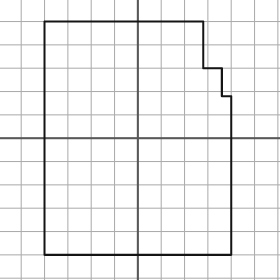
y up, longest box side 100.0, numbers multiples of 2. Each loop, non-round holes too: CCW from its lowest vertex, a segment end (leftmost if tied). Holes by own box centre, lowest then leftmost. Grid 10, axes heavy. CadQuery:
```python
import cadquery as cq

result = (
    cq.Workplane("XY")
    .moveTo(-40.0, -50.0)
    .lineTo(40.0, -50.0)
    .lineTo(40.0, 18.0)
    .lineTo(36.0, 18.0)
    .lineTo(36.0, 30.0)
    .lineTo(28.0, 30.0)
    .lineTo(28.0, 50.0)
    .lineTo(-40.0, 50.0)
    .close()
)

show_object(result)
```